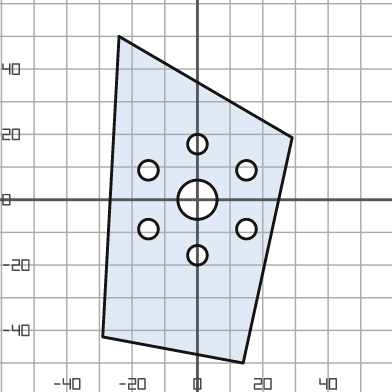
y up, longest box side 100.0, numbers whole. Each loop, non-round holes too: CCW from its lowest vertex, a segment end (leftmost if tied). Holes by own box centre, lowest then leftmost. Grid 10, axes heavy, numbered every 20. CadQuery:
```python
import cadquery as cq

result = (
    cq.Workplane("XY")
    .moveTo(14.0, -50.0)
    .lineTo(29.0, 19.0)
    .lineTo(-24.0, 50.0)
    .lineTo(-29.0, -42.0)
    .close()
    .moveTo(0.0, -17.0)
    .circle(3.0)
    .moveTo(-15.0, -9.0)
    .circle(3.0)
    .moveTo(15.0, -9.0)
    .circle(3.0)
    .moveTo(0.0, 0.0)
    .circle(6.0)
    .moveTo(-15.0, 9.0)
    .circle(3.0)
    .moveTo(15.0, 9.0)
    .circle(3.0)
    .moveTo(0.0, 17.0)
    .circle(3.0)
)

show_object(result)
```